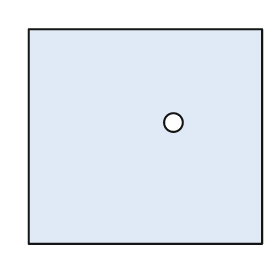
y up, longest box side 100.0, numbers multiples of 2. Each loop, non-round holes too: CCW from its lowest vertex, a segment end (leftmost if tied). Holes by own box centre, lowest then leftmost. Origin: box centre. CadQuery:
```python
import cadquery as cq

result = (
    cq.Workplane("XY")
    .moveTo(-50.0, -46.0)
    .lineTo(50.0, -46.0)
    .lineTo(50.0, 46.0)
    .lineTo(-50.0, 46.0)
    .close()
    .moveTo(12.0, 6.0)
    .circle(4.0)
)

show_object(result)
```